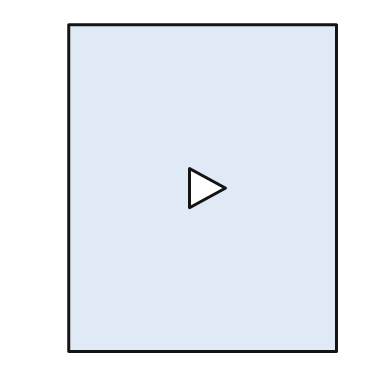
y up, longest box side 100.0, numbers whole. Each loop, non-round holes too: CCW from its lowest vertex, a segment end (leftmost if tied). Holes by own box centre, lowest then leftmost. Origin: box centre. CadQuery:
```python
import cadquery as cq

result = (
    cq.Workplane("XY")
    .moveTo(-41.0, -50.0)
    .lineTo(41.0, -50.0)
    .lineTo(41.0, 50.0)
    .lineTo(-41.0, 50.0)
    .close()
    .moveTo(-4.0, -6.0)
    .lineTo(7.0, 0.0)
    .lineTo(-4.0, 6.0)
    .close()
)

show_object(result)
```